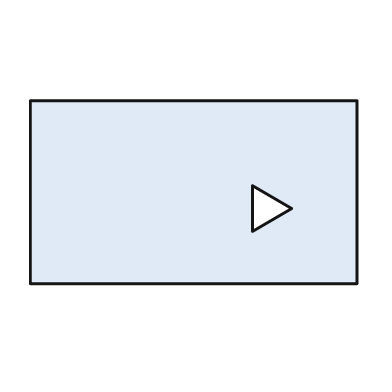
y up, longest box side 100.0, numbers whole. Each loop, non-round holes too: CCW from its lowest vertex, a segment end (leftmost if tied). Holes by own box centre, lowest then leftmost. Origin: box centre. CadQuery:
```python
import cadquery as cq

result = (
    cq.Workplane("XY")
    .moveTo(-50.0, -28.0)
    .lineTo(50.0, -28.0)
    .lineTo(50.0, 28.0)
    .lineTo(-50.0, 28.0)
    .close()
    .moveTo(18.0, -12.0)
    .lineTo(30.0, -5.0)
    .lineTo(18.0, 2.0)
    .close()
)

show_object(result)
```